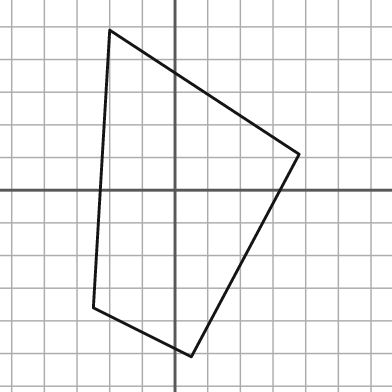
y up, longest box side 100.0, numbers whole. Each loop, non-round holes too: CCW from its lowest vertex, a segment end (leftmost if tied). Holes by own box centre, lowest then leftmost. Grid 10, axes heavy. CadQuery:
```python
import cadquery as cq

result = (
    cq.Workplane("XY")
    .moveTo(5.0, -51.0)
    .lineTo(38.0, 11.0)
    .lineTo(-20.0, 49.0)
    .lineTo(-25.0, -36.0)
    .close()
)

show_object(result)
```